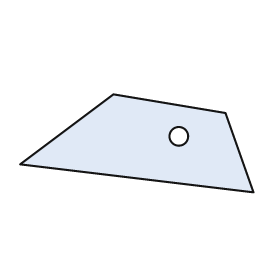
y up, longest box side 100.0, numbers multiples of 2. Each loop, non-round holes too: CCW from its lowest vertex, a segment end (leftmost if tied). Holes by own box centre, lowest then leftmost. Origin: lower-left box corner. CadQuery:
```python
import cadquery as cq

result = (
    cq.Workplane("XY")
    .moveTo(100.0, 0.0)
    .lineTo(88.0, 34.0)
    .lineTo(40.0, 42.0)
    .lineTo(0.0, 12.0)
    .close()
    .moveTo(68.0, 24.0)
    .circle(4.0)
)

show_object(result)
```